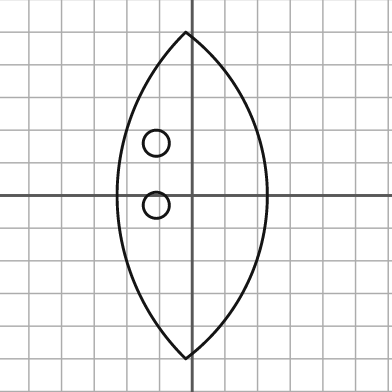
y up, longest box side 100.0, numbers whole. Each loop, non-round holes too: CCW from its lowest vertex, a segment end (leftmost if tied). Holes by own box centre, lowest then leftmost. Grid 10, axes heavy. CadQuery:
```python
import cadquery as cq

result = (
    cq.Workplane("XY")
    .moveTo(-2.0, -50.0)
    .threePointArc((23.0, 0.0), (-2.0, 50.0))
    .threePointArc((-23.0, 0.0), (-2.0, -50.0))
    .close()
    .moveTo(-11.0, -3.0)
    .circle(4.0)
    .moveTo(-11.0, 16.0)
    .circle(4.0)
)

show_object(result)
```